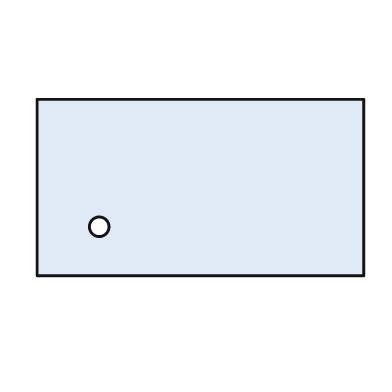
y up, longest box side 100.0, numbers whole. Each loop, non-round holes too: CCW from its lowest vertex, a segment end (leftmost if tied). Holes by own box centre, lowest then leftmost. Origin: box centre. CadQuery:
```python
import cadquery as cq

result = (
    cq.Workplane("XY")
    .moveTo(-50.0, -27.0)
    .lineTo(50.0, -27.0)
    .lineTo(50.0, 27.0)
    .lineTo(-50.0, 27.0)
    .close()
    .moveTo(-31.0, -12.0)
    .circle(3.0)
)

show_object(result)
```